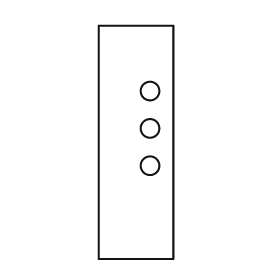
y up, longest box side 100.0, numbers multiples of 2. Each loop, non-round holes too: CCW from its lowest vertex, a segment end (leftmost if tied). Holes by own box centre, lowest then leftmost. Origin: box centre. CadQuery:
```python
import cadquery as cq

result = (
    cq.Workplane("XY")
    .moveTo(-16.0, -50.0)
    .lineTo(16.0, -50.0)
    .lineTo(16.0, 50.0)
    .lineTo(-16.0, 50.0)
    .close()
    .moveTo(6.0, -10.0)
    .circle(4.0)
    .moveTo(6.0, 6.0)
    .circle(4.0)
    .moveTo(6.0, 22.0)
    .circle(4.0)
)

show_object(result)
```